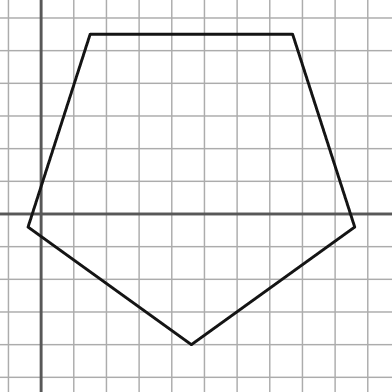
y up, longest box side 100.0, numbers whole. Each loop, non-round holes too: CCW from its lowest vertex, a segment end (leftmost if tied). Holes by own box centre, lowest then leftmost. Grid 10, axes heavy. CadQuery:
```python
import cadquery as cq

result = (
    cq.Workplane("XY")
    .moveTo(46.0, -40.0)
    .lineTo(96.0, -4.0)
    .lineTo(77.0, 55.0)
    .lineTo(15.0, 55.0)
    .lineTo(-4.0, -4.0)
    .close()
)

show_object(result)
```